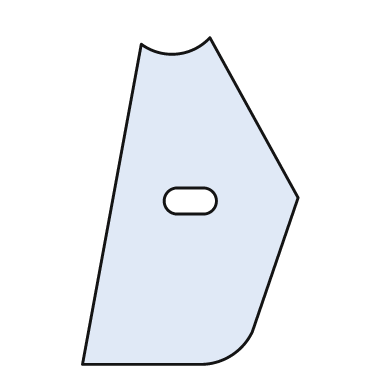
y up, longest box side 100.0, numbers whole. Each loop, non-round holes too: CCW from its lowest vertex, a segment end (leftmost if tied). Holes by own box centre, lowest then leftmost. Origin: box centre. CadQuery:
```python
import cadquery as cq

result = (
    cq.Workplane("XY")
    .moveTo(-33.0, -50.0)
    .lineTo(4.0, -50.0)
    .threePointArc((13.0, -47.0), (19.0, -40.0))
    .lineTo(33.0, 1.0)
    .lineTo(6.0, 50.0)
    .threePointArc((-4.0, 45.0), (-15.0, 48.0))
    .close()
    .moveTo(-4.0, -4.0)
    .lineTo(4.0, -4.0)
    .threePointArc((8.0, 0.0), (4.0, 4.0))
    .lineTo(-4.0, 4.0)
    .threePointArc((-8.0, 0.0), (-4.0, -4.0))
    .close()
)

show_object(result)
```